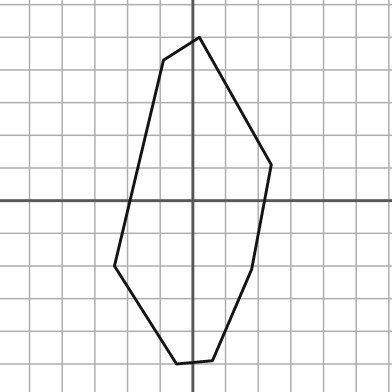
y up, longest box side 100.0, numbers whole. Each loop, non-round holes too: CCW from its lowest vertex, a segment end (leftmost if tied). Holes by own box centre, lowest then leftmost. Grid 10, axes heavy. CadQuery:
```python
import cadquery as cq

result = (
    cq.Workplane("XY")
    .moveTo(-5.0, -50.0)
    .lineTo(6.0, -49.0)
    .lineTo(18.0, -21.0)
    .lineTo(24.0, 11.0)
    .lineTo(2.0, 50.0)
    .lineTo(-9.0, 43.0)
    .lineTo(-24.0, -20.0)
    .close()
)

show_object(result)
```